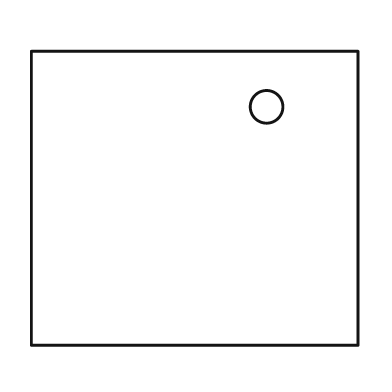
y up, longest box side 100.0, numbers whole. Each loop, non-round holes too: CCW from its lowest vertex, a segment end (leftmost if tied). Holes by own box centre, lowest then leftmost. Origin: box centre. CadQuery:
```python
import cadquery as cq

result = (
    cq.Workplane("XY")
    .moveTo(-50.0, -45.0)
    .lineTo(50.0, -45.0)
    .lineTo(50.0, 45.0)
    .lineTo(-50.0, 45.0)
    .close()
    .moveTo(22.0, 28.0)
    .circle(5.0)
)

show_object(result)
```